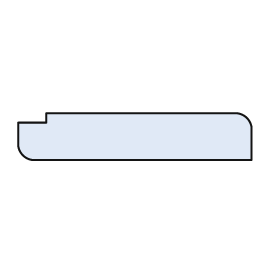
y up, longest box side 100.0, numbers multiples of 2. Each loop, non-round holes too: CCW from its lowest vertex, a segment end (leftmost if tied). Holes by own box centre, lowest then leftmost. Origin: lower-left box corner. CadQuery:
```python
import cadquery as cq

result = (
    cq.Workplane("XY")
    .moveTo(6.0, 0.0)
    .lineTo(100.0, 0.0)
    .lineTo(100.0, 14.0)
    .threePointArc((98.0, 18.0), (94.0, 20.0))
    .lineTo(12.0, 20.0)
    .lineTo(12.0, 16.0)
    .lineTo(0.0, 16.0)
    .lineTo(0.0, 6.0)
    .threePointArc((2.0, 2.0), (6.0, 0.0))
    .close()
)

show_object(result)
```